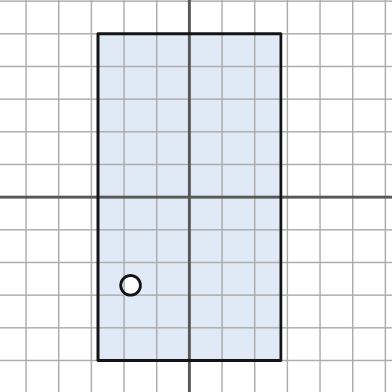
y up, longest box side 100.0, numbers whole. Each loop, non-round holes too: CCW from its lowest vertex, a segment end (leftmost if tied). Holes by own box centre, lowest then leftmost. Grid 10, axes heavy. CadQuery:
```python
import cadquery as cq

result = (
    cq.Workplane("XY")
    .moveTo(-28.0, -50.0)
    .lineTo(28.0, -50.0)
    .lineTo(28.0, 50.0)
    .lineTo(-28.0, 50.0)
    .close()
    .moveTo(-18.0, -27.0)
    .circle(3.0)
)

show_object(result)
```